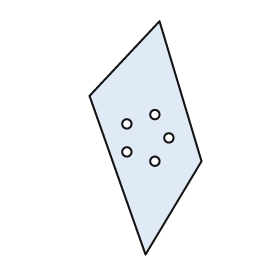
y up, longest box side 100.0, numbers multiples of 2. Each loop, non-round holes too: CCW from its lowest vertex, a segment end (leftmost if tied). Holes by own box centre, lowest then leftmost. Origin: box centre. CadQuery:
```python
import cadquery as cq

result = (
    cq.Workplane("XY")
    .moveTo(0.0, -50.0)
    .lineTo(24.0, -10.0)
    .lineTo(6.0, 50.0)
    .lineTo(-24.0, 18.0)
    .close()
    .moveTo(4.0, -10.0)
    .circle(2.0)
    .moveTo(-8.0, -6.0)
    .circle(2.0)
    .moveTo(10.0, 0.0)
    .circle(2.0)
    .moveTo(-8.0, 6.0)
    .circle(2.0)
    .moveTo(4.0, 10.0)
    .circle(2.0)
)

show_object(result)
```